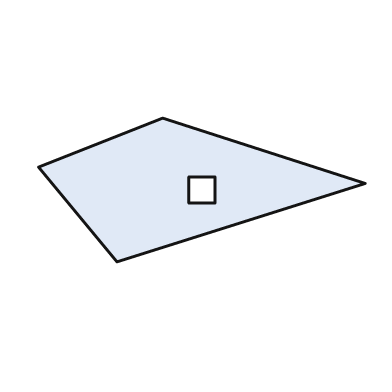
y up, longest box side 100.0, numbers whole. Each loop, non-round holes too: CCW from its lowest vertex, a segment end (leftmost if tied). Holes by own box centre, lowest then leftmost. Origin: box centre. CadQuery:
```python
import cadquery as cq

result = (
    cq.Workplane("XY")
    .moveTo(-26.0, -22.0)
    .lineTo(50.0, 2.0)
    .lineTo(-12.0, 22.0)
    .lineTo(-50.0, 7.0)
    .close()
    .moveTo(-4.0, -4.0)
    .lineTo(4.0, -4.0)
    .lineTo(4.0, 4.0)
    .lineTo(-4.0, 4.0)
    .close()
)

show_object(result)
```